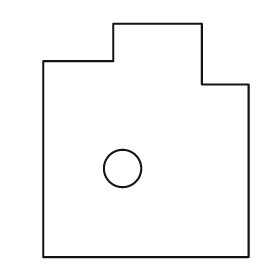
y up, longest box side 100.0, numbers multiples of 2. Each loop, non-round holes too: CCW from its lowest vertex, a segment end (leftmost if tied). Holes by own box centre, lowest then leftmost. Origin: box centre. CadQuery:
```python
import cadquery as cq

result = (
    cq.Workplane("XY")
    .moveTo(-44.0, -50.0)
    .lineTo(44.0, -50.0)
    .lineTo(44.0, 24.0)
    .lineTo(24.0, 24.0)
    .lineTo(24.0, 50.0)
    .lineTo(-14.0, 50.0)
    .lineTo(-14.0, 34.0)
    .lineTo(-44.0, 34.0)
    .close()
    .moveTo(-10.0, -12.0)
    .circle(8.0)
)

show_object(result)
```